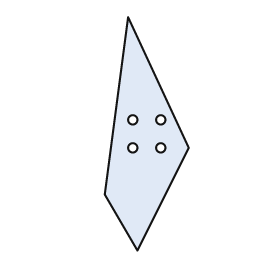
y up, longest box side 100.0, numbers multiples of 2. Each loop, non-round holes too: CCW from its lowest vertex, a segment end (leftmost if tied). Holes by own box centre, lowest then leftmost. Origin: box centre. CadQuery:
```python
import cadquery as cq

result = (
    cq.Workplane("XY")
    .moveTo(-4.0, -50.0)
    .lineTo(18.0, -6.0)
    .lineTo(-8.0, 50.0)
    .lineTo(-18.0, -26.0)
    .close()
    .moveTo(-6.0, -6.0)
    .circle(2.0)
    .moveTo(6.0, -6.0)
    .circle(2.0)
    .moveTo(-6.0, 6.0)
    .circle(2.0)
    .moveTo(6.0, 6.0)
    .circle(2.0)
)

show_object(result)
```